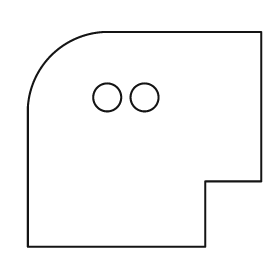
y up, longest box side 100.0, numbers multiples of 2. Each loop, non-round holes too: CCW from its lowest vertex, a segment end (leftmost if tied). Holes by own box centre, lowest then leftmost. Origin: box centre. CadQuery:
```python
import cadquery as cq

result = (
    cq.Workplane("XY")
    .moveTo(-50.0, -46.0)
    .lineTo(26.0, -46.0)
    .lineTo(26.0, -18.0)
    .lineTo(50.0, -18.0)
    .lineTo(50.0, 46.0)
    .lineTo(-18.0, 46.0)
    .threePointArc((-40.0, 36.0), (-50.0, 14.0))
    .close()
    .moveTo(-16.0, 18.0)
    .circle(6.0)
    .moveTo(0.0, 18.0)
    .circle(6.0)
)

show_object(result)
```